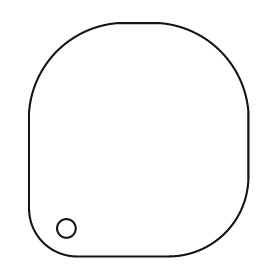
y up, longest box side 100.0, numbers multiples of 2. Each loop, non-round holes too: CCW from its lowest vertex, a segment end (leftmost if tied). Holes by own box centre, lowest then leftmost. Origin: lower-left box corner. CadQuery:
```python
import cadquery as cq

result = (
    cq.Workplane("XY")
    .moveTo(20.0, 0.0)
    .lineTo(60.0, 0.0)
    .threePointArc((84.0, 10.0), (94.0, 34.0))
    .lineTo(94.0, 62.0)
    .threePointArc((82.0, 88.0), (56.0, 100.0))
    .lineTo(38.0, 100.0)
    .threePointArc((12.0, 88.0), (0.0, 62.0))
    .lineTo(0.0, 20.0)
    .threePointArc((6.0, 6.0), (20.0, 0.0))
    .close()
    .moveTo(16.0, 12.0)
    .circle(4.0)
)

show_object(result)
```